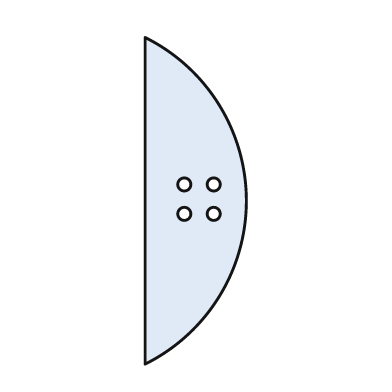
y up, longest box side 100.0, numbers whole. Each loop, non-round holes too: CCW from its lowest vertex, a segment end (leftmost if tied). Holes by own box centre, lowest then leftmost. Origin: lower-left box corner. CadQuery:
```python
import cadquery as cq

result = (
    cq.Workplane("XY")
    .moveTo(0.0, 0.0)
    .threePointArc((31.0, 50.0), (0.0, 100.0))
    .close()
    .moveTo(12.0, 46.0)
    .circle(2.0)
    .moveTo(21.0, 46.0)
    .circle(2.0)
    .moveTo(12.0, 55.0)
    .circle(2.0)
    .moveTo(21.0, 55.0)
    .circle(2.0)
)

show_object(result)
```